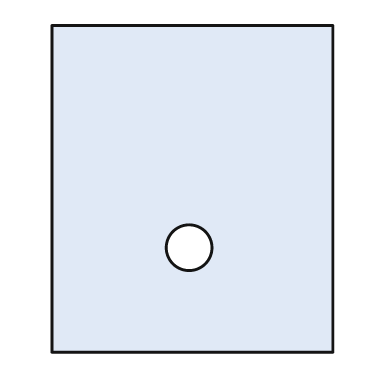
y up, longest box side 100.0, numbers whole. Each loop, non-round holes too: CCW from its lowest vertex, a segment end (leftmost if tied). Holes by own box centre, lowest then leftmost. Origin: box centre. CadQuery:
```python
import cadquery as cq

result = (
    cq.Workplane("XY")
    .moveTo(-43.0, -50.0)
    .lineTo(43.0, -50.0)
    .lineTo(43.0, 50.0)
    .lineTo(-43.0, 50.0)
    .close()
    .moveTo(-1.0, -18.0)
    .circle(7.0)
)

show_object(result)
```